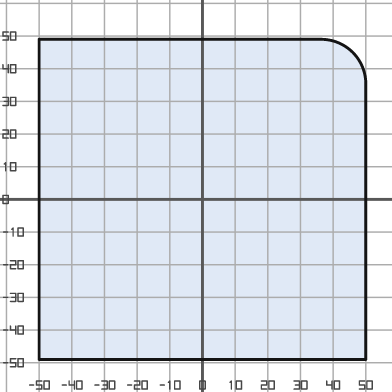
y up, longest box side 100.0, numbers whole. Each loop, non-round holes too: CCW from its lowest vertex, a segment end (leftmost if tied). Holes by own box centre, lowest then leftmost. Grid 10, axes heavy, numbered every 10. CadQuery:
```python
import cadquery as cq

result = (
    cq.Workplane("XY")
    .moveTo(-50.0, -49.0)
    .lineTo(50.0, -49.0)
    .lineTo(50.0, 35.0)
    .threePointArc((46.0, 45.0), (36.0, 49.0))
    .lineTo(-50.0, 49.0)
    .close()
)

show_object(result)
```